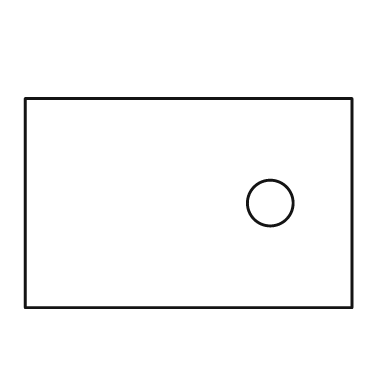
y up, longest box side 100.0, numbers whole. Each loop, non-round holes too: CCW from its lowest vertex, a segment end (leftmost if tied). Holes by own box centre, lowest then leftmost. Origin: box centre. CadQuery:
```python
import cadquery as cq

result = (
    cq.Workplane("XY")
    .moveTo(-50.0, -32.0)
    .lineTo(50.0, -32.0)
    .lineTo(50.0, 32.0)
    .lineTo(-50.0, 32.0)
    .close()
    .moveTo(25.0, 0.0)
    .circle(7.0)
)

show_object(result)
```